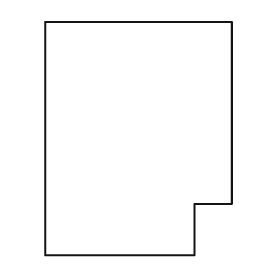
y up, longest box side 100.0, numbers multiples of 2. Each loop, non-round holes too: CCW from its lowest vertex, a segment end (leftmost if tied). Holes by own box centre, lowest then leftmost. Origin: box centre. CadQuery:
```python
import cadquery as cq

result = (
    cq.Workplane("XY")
    .moveTo(-40.0, -50.0)
    .lineTo(24.0, -50.0)
    .lineTo(24.0, -28.0)
    .lineTo(40.0, -28.0)
    .lineTo(40.0, 50.0)
    .lineTo(-40.0, 50.0)
    .close()
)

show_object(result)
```